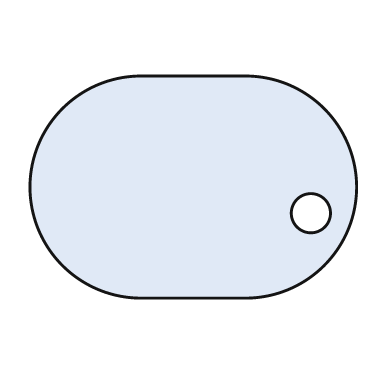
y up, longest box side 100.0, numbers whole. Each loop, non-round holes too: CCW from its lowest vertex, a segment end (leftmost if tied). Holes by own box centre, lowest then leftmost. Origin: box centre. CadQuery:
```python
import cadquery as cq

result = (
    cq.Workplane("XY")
    .moveTo(-16.0, -34.0)
    .lineTo(16.0, -34.0)
    .threePointArc((50.0, 0.0), (16.0, 34.0))
    .lineTo(-16.0, 34.0)
    .threePointArc((-50.0, 0.0), (-16.0, -34.0))
    .close()
    .moveTo(36.0, -8.0)
    .circle(6.0)
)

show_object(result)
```